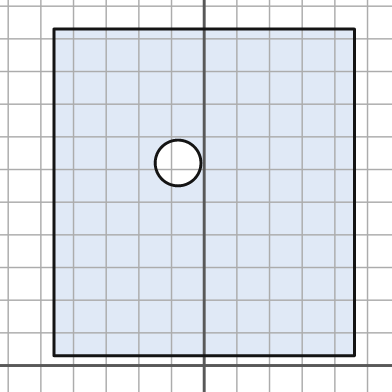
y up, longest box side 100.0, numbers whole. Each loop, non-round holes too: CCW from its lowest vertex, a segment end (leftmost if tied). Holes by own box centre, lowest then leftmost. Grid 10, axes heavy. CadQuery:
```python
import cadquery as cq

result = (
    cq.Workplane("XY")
    .moveTo(-46.0, 3.0)
    .lineTo(46.0, 3.0)
    .lineTo(46.0, 103.0)
    .lineTo(-46.0, 103.0)
    .close()
    .moveTo(-8.0, 62.0)
    .circle(7.0)
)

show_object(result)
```